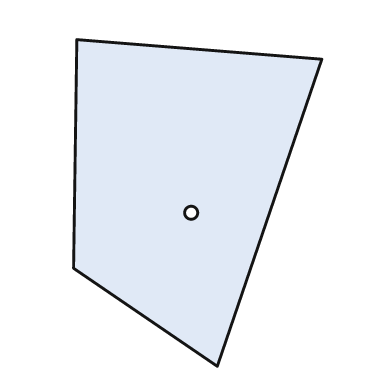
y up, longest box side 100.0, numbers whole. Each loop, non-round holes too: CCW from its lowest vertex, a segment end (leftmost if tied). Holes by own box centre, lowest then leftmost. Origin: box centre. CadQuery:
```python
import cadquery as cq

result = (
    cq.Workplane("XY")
    .moveTo(6.0, -50.0)
    .lineTo(38.0, 44.0)
    .lineTo(-37.0, 50.0)
    .lineTo(-38.0, -20.0)
    .close()
    .moveTo(-2.0, -3.0)
    .circle(2.0)
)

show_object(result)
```